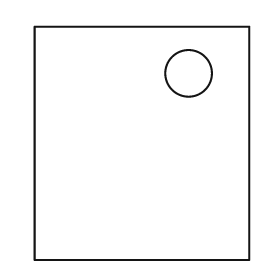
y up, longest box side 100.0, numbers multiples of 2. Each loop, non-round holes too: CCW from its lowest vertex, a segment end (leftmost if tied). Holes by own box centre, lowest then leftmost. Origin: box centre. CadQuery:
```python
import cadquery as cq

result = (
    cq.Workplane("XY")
    .moveTo(-46.0, -50.0)
    .lineTo(46.0, -50.0)
    .lineTo(46.0, 50.0)
    .lineTo(-46.0, 50.0)
    .close()
    .moveTo(20.0, 30.0)
    .circle(10.0)
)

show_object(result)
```